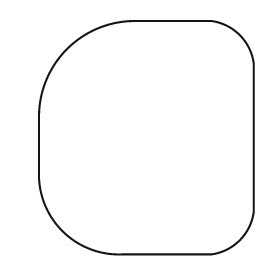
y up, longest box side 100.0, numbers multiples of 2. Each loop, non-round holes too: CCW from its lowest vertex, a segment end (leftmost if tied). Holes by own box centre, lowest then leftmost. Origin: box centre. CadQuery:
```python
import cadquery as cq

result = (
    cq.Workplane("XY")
    .moveTo(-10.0, -50.0)
    .lineTo(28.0, -50.0)
    .threePointArc((40.0, -44.0), (46.0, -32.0))
    .lineTo(46.0, 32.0)
    .threePointArc((40.0, 44.0), (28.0, 50.0))
    .lineTo(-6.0, 50.0)
    .threePointArc((-34.0, 38.0), (-46.0, 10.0))
    .lineTo(-46.0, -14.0)
    .threePointArc((-36.0, -40.0), (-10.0, -50.0))
    .close()
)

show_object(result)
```